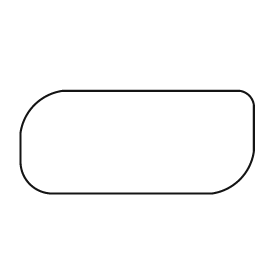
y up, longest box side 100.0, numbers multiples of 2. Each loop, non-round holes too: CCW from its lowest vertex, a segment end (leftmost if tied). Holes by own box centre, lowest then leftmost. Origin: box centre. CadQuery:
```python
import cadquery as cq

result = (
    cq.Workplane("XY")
    .moveTo(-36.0, -22.0)
    .lineTo(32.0, -22.0)
    .threePointArc((44.0, -16.0), (50.0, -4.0))
    .lineTo(50.0, 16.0)
    .threePointArc((48.0, 20.0), (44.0, 22.0))
    .lineTo(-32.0, 22.0)
    .threePointArc((-44.0, 16.0), (-50.0, 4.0))
    .lineTo(-50.0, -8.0)
    .threePointArc((-46.0, -18.0), (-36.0, -22.0))
    .close()
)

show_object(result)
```